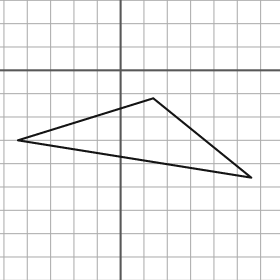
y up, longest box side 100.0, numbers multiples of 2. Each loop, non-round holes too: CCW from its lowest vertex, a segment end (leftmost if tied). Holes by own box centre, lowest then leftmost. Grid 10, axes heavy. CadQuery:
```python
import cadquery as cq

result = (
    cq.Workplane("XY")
    .moveTo(56.0, -46.0)
    .lineTo(14.0, -12.0)
    .lineTo(-44.0, -30.0)
    .close()
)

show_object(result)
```